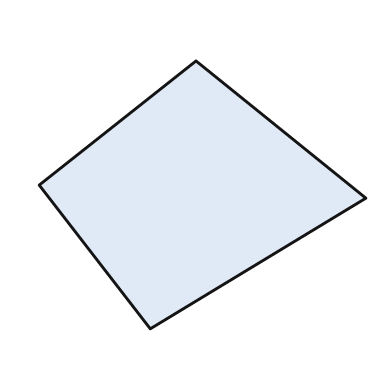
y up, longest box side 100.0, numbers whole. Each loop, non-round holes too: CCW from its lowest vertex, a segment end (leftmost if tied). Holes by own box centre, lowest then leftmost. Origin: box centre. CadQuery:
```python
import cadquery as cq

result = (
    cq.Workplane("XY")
    .moveTo(-16.0, -41.0)
    .lineTo(50.0, -1.0)
    .lineTo(-2.0, 41.0)
    .lineTo(-50.0, 3.0)
    .close()
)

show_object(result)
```